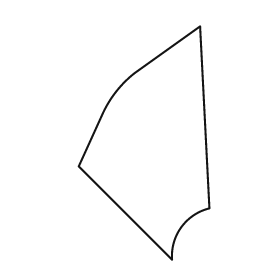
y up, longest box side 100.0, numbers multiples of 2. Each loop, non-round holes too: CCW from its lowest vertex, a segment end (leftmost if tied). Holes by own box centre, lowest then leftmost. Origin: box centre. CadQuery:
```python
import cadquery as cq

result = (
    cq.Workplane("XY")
    .moveTo(12.0, -50.0)
    .threePointArc((16.0, -36.0), (28.0, -28.0))
    .lineTo(24.0, 50.0)
    .lineTo(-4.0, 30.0)
    .threePointArc((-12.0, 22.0), (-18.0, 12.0))
    .lineTo(-28.0, -10.0)
    .close()
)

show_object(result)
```